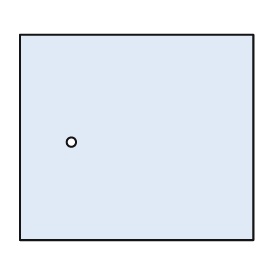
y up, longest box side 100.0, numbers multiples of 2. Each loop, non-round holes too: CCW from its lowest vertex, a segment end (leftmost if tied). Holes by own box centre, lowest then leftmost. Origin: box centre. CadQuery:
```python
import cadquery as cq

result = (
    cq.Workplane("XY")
    .moveTo(-50.0, -44.0)
    .lineTo(50.0, -44.0)
    .lineTo(50.0, 44.0)
    .lineTo(-50.0, 44.0)
    .close()
    .moveTo(-28.0, -2.0)
    .circle(2.0)
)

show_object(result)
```